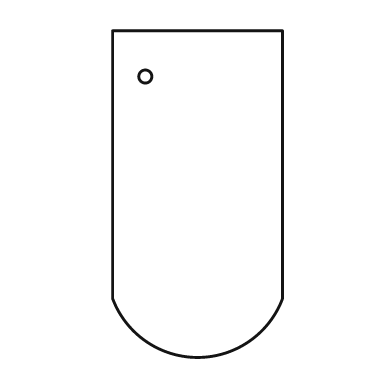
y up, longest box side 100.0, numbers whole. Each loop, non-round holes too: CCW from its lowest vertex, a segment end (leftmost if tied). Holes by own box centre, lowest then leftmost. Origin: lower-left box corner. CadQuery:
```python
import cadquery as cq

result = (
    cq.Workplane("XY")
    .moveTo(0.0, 18.0)
    .threePointArc((26.0, 0.0), (52.0, 18.0))
    .lineTo(52.0, 100.0)
    .lineTo(0.0, 100.0)
    .close()
    .moveTo(10.0, 86.0)
    .circle(2.0)
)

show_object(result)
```